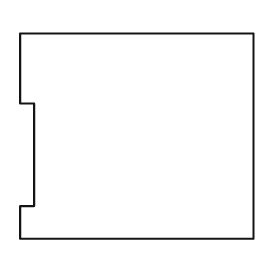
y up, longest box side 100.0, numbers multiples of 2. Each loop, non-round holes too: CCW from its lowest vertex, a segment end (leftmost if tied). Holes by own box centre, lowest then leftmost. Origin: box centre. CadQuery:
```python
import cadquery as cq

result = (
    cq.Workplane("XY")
    .moveTo(-50.0, -44.0)
    .lineTo(50.0, -44.0)
    .lineTo(50.0, 44.0)
    .lineTo(-50.0, 44.0)
    .lineTo(-50.0, 14.0)
    .lineTo(-44.0, 14.0)
    .lineTo(-44.0, -30.0)
    .lineTo(-50.0, -30.0)
    .close()
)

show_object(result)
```